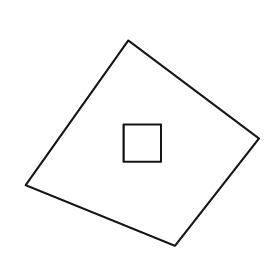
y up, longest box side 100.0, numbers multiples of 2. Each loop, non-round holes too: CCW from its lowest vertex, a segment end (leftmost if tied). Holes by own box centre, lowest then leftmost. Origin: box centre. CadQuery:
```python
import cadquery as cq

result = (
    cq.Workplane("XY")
    .moveTo(14.0, -44.0)
    .lineTo(50.0, 2.0)
    .lineTo(-6.0, 44.0)
    .lineTo(-50.0, -18.0)
    .close()
    .moveTo(-8.0, -8.0)
    .lineTo(8.0, -8.0)
    .lineTo(8.0, 8.0)
    .lineTo(-8.0, 8.0)
    .close()
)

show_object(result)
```